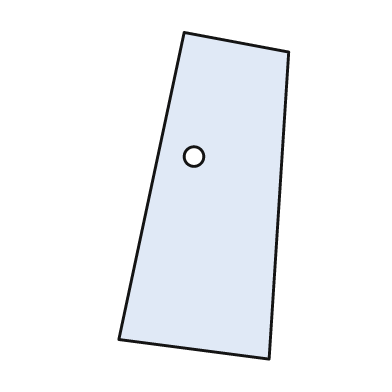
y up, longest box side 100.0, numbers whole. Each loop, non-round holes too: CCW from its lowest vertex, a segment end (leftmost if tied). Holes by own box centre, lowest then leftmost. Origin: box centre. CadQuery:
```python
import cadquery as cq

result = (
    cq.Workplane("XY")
    .moveTo(20.0, -50.0)
    .lineTo(26.0, 44.0)
    .lineTo(-6.0, 50.0)
    .lineTo(-26.0, -44.0)
    .close()
    .moveTo(-3.0, 12.0)
    .circle(3.0)
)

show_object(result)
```